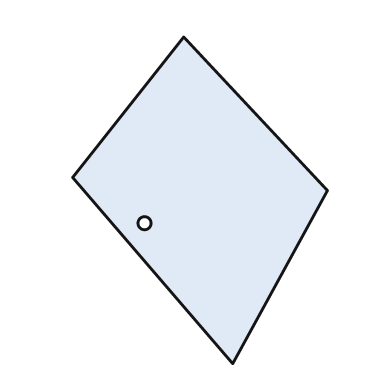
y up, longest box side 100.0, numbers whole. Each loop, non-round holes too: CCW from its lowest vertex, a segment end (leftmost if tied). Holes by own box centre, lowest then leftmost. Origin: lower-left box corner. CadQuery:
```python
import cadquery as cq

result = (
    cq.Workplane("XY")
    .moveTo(49.0, 0.0)
    .lineTo(78.0, 53.0)
    .lineTo(34.0, 100.0)
    .lineTo(0.0, 57.0)
    .close()
    .moveTo(22.0, 43.0)
    .circle(2.0)
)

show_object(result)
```